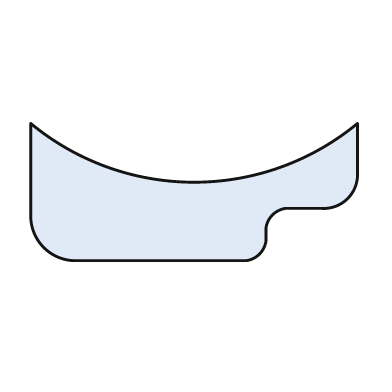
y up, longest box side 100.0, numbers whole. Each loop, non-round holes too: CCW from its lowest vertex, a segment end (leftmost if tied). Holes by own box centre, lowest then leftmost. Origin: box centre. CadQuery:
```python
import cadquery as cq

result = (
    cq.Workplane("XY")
    .moveTo(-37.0, -21.0)
    .lineTo(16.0, -21.0)
    .threePointArc((20.0, -19.0), (22.0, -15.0))
    .lineTo(22.0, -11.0)
    .threePointArc((24.0, -7.0), (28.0, -5.0))
    .lineTo(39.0, -5.0)
    .threePointArc((47.0, -2.0), (50.0, 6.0))
    .lineTo(50.0, 21.0)
    .threePointArc((0.0, 3.0), (-50.0, 21.0))
    .lineTo(-50.0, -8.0)
    .threePointArc((-46.0, -17.0), (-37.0, -21.0))
    .close()
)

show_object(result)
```